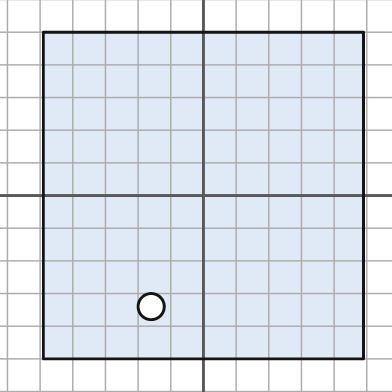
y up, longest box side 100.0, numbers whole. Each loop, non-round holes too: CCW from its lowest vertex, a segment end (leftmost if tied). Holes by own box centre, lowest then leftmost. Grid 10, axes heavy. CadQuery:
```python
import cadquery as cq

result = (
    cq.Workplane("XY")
    .moveTo(-49.0, -50.0)
    .lineTo(49.0, -50.0)
    .lineTo(49.0, 50.0)
    .lineTo(-49.0, 50.0)
    .close()
    .moveTo(-16.0, -34.0)
    .circle(4.0)
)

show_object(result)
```